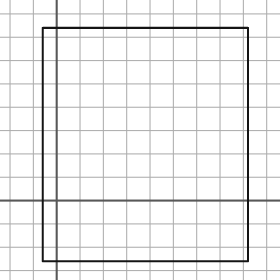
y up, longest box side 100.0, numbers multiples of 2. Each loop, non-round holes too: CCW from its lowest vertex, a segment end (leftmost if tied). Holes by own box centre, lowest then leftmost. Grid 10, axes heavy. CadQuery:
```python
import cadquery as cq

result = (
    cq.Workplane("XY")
    .moveTo(-6.0, -26.0)
    .lineTo(82.0, -26.0)
    .lineTo(82.0, 74.0)
    .lineTo(-6.0, 74.0)
    .close()
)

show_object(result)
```